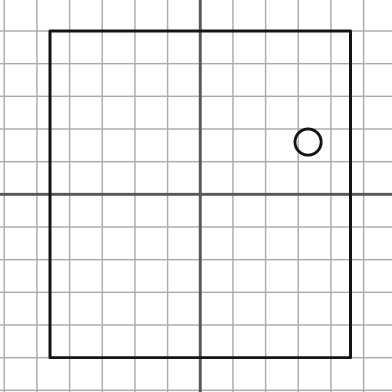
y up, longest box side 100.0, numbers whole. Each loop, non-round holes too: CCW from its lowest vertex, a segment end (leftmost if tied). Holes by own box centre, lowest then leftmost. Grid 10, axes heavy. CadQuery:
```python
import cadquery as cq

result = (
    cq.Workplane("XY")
    .moveTo(-46.0, -50.0)
    .lineTo(46.0, -50.0)
    .lineTo(46.0, 50.0)
    .lineTo(-46.0, 50.0)
    .close()
    .moveTo(33.0, 16.0)
    .circle(4.0)
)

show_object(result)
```